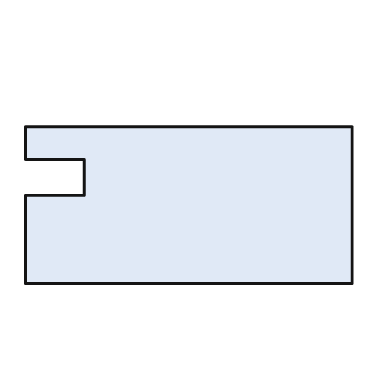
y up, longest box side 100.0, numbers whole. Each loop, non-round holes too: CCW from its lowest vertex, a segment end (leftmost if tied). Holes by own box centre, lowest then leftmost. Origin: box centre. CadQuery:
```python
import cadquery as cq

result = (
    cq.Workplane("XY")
    .moveTo(-50.0, -24.0)
    .lineTo(50.0, -24.0)
    .lineTo(50.0, 24.0)
    .lineTo(-50.0, 24.0)
    .lineTo(-50.0, 14.0)
    .lineTo(-32.0, 14.0)
    .lineTo(-32.0, 3.0)
    .lineTo(-50.0, 3.0)
    .close()
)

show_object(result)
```